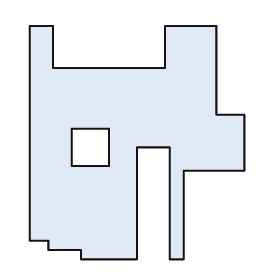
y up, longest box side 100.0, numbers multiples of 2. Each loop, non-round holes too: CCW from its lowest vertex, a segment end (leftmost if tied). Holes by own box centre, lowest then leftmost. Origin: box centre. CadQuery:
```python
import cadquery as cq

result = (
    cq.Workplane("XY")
    .moveTo(-24.0, -50.0)
    .lineTo(0.0, -50.0)
    .lineTo(0.0, -2.0)
    .lineTo(14.0, -2.0)
    .lineTo(14.0, -50.0)
    .lineTo(20.0, -50.0)
    .lineTo(20.0, -12.0)
    .lineTo(46.0, -12.0)
    .lineTo(46.0, 12.0)
    .lineTo(34.0, 12.0)
    .lineTo(34.0, 50.0)
    .lineTo(12.0, 50.0)
    .lineTo(12.0, 32.0)
    .lineTo(-36.0, 32.0)
    .lineTo(-36.0, 50.0)
    .lineTo(-46.0, 50.0)
    .lineTo(-46.0, -42.0)
    .lineTo(-38.0, -42.0)
    .lineTo(-38.0, -46.0)
    .lineTo(-24.0, -46.0)
    .close()
    .moveTo(-28.0, -10.0)
    .lineTo(-12.0, -10.0)
    .lineTo(-12.0, 6.0)
    .lineTo(-28.0, 6.0)
    .close()
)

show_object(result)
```